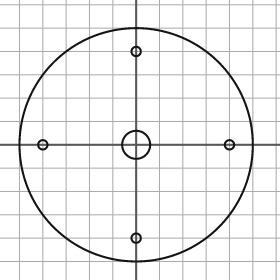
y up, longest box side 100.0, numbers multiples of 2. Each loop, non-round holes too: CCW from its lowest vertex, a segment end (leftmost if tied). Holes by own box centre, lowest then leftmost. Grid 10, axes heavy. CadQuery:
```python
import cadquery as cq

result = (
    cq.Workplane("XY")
    .moveTo(0.0, 0.0)
    .circle(50.0)
    .moveTo(0.0, -40.0)
    .circle(2.0)
    .moveTo(-40.0, 0.0)
    .circle(2.0)
    .moveTo(0.0, 0.0)
    .circle(6.0)
    .moveTo(40.0, 0.0)
    .circle(2.0)
    .moveTo(0.0, 40.0)
    .circle(2.0)
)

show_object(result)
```